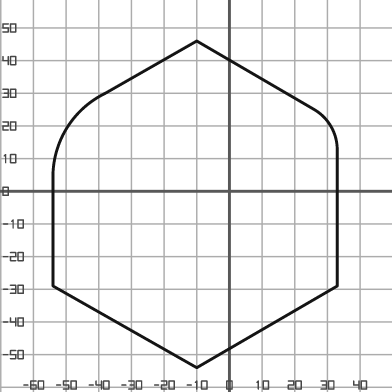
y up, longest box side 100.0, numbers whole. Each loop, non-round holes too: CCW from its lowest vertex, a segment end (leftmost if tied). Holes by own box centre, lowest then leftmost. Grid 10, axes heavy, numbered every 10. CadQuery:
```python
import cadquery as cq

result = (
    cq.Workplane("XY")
    .moveTo(-10.0, -54.0)
    .lineTo(33.0, -29.0)
    .lineTo(33.0, 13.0)
    .threePointArc((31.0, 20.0), (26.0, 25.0))
    .lineTo(-10.0, 46.0)
    .lineTo(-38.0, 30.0)
    .threePointArc((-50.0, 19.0), (-54.0, 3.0))
    .lineTo(-54.0, -29.0)
    .close()
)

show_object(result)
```